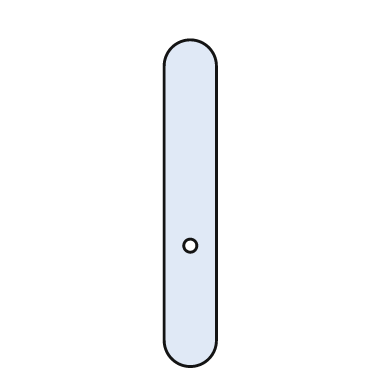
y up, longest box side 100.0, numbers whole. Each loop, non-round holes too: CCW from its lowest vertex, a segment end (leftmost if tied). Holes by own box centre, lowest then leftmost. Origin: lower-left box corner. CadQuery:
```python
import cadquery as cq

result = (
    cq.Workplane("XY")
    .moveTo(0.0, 8.0)
    .threePointArc((8.0, 0.0), (16.0, 8.0))
    .lineTo(16.0, 92.0)
    .threePointArc((8.0, 100.0), (0.0, 92.0))
    .close()
    .moveTo(8.0, 37.0)
    .circle(2.0)
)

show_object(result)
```